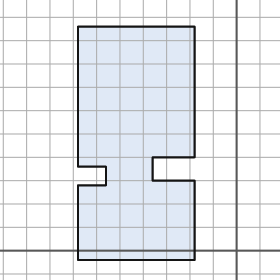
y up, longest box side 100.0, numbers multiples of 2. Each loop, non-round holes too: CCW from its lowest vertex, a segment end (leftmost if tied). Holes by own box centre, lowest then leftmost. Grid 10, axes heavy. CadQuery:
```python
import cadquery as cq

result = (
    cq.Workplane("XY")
    .moveTo(-68.0, -4.0)
    .lineTo(-18.0, -4.0)
    .lineTo(-18.0, 30.0)
    .lineTo(-36.0, 30.0)
    .lineTo(-36.0, 40.0)
    .lineTo(-18.0, 40.0)
    .lineTo(-18.0, 96.0)
    .lineTo(-68.0, 96.0)
    .lineTo(-68.0, 36.0)
    .lineTo(-56.0, 36.0)
    .lineTo(-56.0, 28.0)
    .lineTo(-68.0, 28.0)
    .close()
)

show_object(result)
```